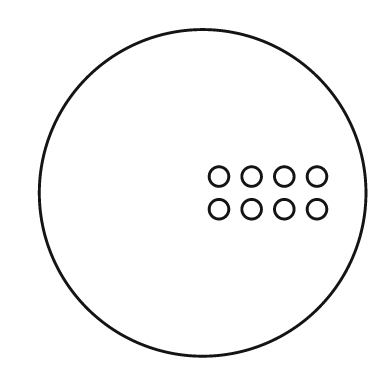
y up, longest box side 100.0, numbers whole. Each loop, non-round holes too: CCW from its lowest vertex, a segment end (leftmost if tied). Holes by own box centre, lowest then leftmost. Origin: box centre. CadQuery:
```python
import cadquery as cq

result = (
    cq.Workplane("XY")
    .moveTo(0.0, 0.0)
    .circle(50.0)
    .moveTo(5.0, -5.0)
    .circle(3.0)
    .moveTo(15.0, -5.0)
    .circle(3.0)
    .moveTo(25.0, -5.0)
    .circle(3.0)
    .moveTo(35.0, -5.0)
    .circle(3.0)
    .moveTo(5.0, 5.0)
    .circle(3.0)
    .moveTo(15.0, 5.0)
    .circle(3.0)
    .moveTo(25.0, 5.0)
    .circle(3.0)
    .moveTo(35.0, 5.0)
    .circle(3.0)
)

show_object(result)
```